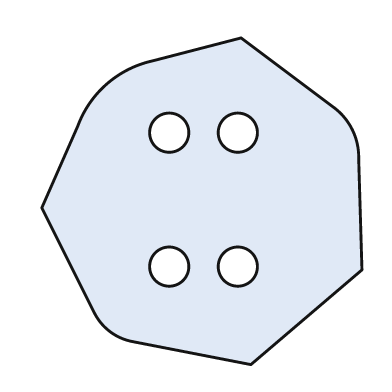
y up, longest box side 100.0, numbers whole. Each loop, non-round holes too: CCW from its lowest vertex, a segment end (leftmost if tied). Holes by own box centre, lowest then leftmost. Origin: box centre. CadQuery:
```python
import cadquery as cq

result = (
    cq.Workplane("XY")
    .moveTo(15.0, -50.0)
    .lineTo(49.0, -21.0)
    .lineTo(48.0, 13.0)
    .threePointArc((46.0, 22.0), (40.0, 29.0))
    .lineTo(12.0, 50.0)
    .lineTo(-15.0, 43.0)
    .threePointArc((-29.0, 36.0), (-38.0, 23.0))
    .lineTo(-49.0, -2.0)
    .lineTo(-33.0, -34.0)
    .threePointArc((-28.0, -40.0), (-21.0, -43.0))
    .close()
    .moveTo(-10.0, -20.0)
    .circle(6.0)
    .moveTo(11.0, -20.0)
    .circle(6.0)
    .moveTo(-10.0, 21.0)
    .circle(6.0)
    .moveTo(11.0, 21.0)
    .circle(6.0)
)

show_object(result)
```